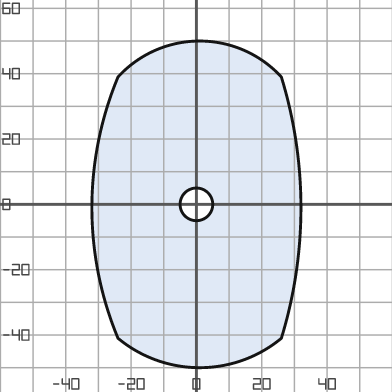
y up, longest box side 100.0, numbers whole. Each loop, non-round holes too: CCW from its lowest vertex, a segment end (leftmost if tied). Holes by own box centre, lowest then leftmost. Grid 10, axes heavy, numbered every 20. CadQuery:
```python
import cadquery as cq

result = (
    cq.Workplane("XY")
    .moveTo(-24.0, -41.0)
    .threePointArc((1.0, -50.0), (26.0, -41.0))
    .threePointArc((32.0, -1.0), (26.0, 39.0))
    .threePointArc((1.0, 50.0), (-24.0, 39.0))
    .threePointArc((-32.0, -1.0), (-24.0, -41.0))
    .close()
    .moveTo(0.0, 0.0)
    .circle(5.0)
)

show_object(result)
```